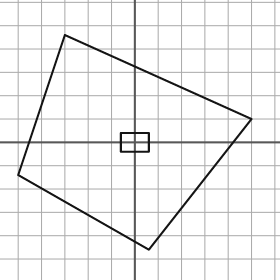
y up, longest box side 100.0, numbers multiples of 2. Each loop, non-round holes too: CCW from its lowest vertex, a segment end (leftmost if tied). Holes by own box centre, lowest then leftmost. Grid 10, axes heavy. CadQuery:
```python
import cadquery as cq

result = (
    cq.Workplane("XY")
    .moveTo(6.0, -46.0)
    .lineTo(50.0, 10.0)
    .lineTo(-30.0, 46.0)
    .lineTo(-50.0, -14.0)
    .close()
    .moveTo(-6.0, -4.0)
    .lineTo(6.0, -4.0)
    .lineTo(6.0, 4.0)
    .lineTo(-6.0, 4.0)
    .close()
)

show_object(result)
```